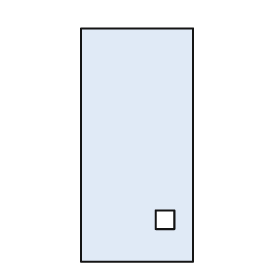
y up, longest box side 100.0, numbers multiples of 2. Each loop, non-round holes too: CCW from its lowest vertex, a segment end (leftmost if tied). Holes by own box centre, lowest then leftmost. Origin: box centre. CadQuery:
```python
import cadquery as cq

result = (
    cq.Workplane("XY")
    .moveTo(-24.0, -50.0)
    .lineTo(24.0, -50.0)
    .lineTo(24.0, 50.0)
    .lineTo(-24.0, 50.0)
    .close()
    .moveTo(8.0, -36.0)
    .lineTo(16.0, -36.0)
    .lineTo(16.0, -28.0)
    .lineTo(8.0, -28.0)
    .close()
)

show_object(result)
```